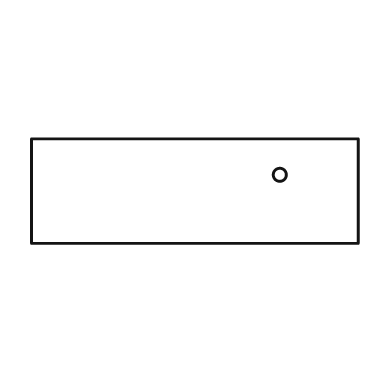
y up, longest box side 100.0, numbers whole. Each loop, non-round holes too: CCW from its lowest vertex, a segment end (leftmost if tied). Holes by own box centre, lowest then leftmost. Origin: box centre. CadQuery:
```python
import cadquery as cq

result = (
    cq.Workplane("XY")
    .moveTo(-50.0, -16.0)
    .lineTo(50.0, -16.0)
    .lineTo(50.0, 16.0)
    .lineTo(-50.0, 16.0)
    .close()
    .moveTo(26.0, 5.0)
    .circle(2.0)
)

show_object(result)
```